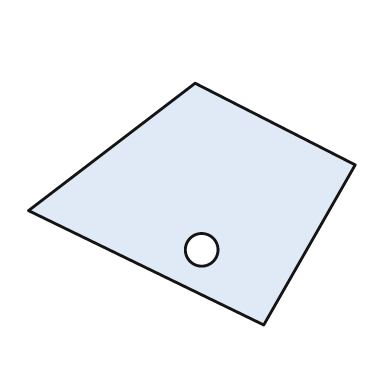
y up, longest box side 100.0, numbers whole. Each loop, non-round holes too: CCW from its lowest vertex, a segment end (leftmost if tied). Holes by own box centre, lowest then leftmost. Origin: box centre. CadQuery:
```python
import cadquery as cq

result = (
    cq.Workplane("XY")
    .moveTo(22.0, -37.0)
    .lineTo(50.0, 12.0)
    .lineTo(1.0, 37.0)
    .lineTo(-50.0, -2.0)
    .close()
    .moveTo(3.0, -14.0)
    .circle(5.0)
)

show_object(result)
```